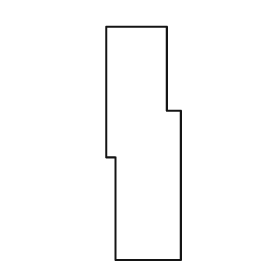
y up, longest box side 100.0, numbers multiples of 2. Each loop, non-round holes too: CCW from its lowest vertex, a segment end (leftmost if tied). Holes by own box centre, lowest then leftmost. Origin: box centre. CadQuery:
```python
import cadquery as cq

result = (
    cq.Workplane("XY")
    .moveTo(-12.0, -50.0)
    .lineTo(16.0, -50.0)
    .lineTo(16.0, 14.0)
    .lineTo(10.0, 14.0)
    .lineTo(10.0, 50.0)
    .lineTo(-16.0, 50.0)
    .lineTo(-16.0, -6.0)
    .lineTo(-12.0, -6.0)
    .close()
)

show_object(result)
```